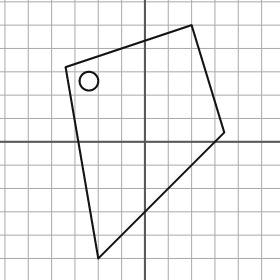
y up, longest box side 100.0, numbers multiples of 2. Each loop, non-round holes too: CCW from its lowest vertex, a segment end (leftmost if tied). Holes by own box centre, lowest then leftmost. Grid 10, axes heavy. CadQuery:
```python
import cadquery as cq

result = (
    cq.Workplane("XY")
    .moveTo(-20.0, -50.0)
    .lineTo(34.0, 4.0)
    .lineTo(20.0, 50.0)
    .lineTo(-34.0, 32.0)
    .close()
    .moveTo(-24.0, 26.0)
    .circle(4.0)
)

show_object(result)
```